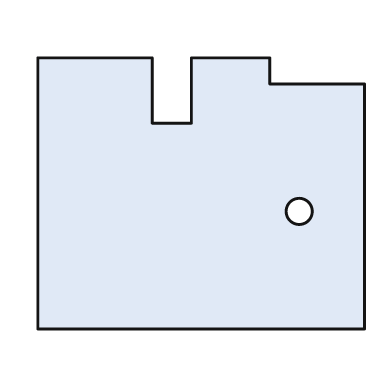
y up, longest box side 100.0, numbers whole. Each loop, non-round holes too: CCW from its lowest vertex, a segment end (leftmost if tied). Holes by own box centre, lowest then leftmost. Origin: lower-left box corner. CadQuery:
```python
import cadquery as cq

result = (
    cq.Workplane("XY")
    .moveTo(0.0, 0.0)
    .lineTo(100.0, 0.0)
    .lineTo(100.0, 75.0)
    .lineTo(71.0, 75.0)
    .lineTo(71.0, 83.0)
    .lineTo(47.0, 83.0)
    .lineTo(47.0, 63.0)
    .lineTo(35.0, 63.0)
    .lineTo(35.0, 83.0)
    .lineTo(0.0, 83.0)
    .close()
    .moveTo(80.0, 36.0)
    .circle(4.0)
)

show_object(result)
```